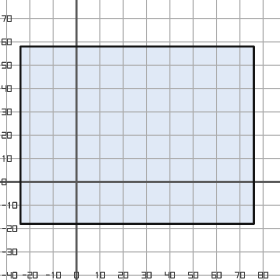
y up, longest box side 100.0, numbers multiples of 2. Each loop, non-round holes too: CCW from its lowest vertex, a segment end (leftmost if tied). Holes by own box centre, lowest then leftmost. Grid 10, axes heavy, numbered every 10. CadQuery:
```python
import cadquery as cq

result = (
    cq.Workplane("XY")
    .moveTo(-24.0, -18.0)
    .lineTo(76.0, -18.0)
    .lineTo(76.0, 58.0)
    .lineTo(-24.0, 58.0)
    .close()
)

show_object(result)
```